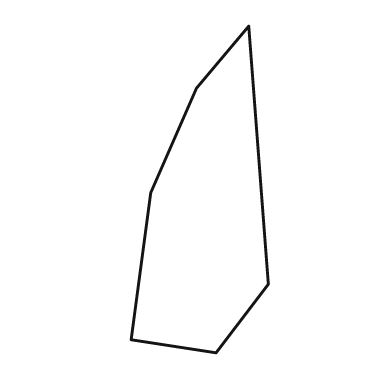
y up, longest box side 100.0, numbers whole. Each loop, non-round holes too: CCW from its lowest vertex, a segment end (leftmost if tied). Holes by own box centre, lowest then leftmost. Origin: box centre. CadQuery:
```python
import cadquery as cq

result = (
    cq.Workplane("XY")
    .moveTo(5.0, -50.0)
    .lineTo(21.0, -29.0)
    .lineTo(15.0, 50.0)
    .lineTo(-1.0, 31.0)
    .lineTo(-15.0, -1.0)
    .lineTo(-21.0, -46.0)
    .close()
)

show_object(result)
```